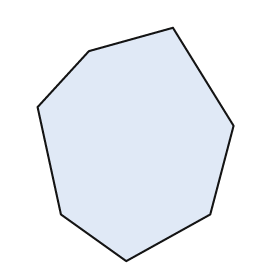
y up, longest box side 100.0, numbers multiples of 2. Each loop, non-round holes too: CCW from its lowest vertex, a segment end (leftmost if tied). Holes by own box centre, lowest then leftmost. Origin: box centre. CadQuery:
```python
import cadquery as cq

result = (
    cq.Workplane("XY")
    .moveTo(-4.0, -50.0)
    .lineTo(32.0, -30.0)
    .lineTo(42.0, 8.0)
    .lineTo(16.0, 50.0)
    .lineTo(-20.0, 40.0)
    .lineTo(-42.0, 16.0)
    .lineTo(-32.0, -30.0)
    .close()
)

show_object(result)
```